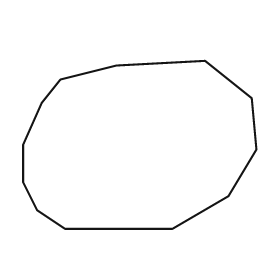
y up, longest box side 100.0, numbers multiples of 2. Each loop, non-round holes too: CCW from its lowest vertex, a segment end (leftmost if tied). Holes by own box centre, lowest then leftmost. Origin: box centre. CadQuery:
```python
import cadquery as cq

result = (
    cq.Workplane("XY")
    .moveTo(-32.0, -36.0)
    .lineTo(14.0, -36.0)
    .lineTo(38.0, -22.0)
    .lineTo(50.0, -2.0)
    .lineTo(48.0, 20.0)
    .lineTo(28.0, 36.0)
    .lineTo(-10.0, 34.0)
    .lineTo(-34.0, 28.0)
    .lineTo(-42.0, 18.0)
    .lineTo(-50.0, 0.0)
    .lineTo(-50.0, -16.0)
    .lineTo(-44.0, -28.0)
    .close()
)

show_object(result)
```